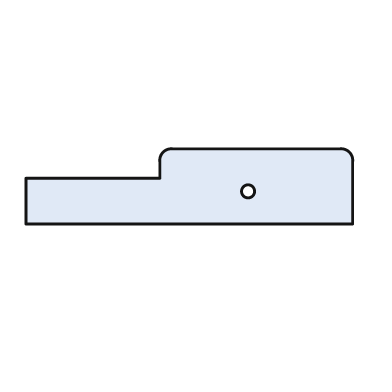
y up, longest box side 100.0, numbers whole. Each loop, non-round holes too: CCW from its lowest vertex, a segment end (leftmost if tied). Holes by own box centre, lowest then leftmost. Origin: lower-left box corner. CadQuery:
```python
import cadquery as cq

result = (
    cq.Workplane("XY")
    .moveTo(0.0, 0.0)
    .lineTo(100.0, 0.0)
    .lineTo(100.0, 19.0)
    .threePointArc((99.0, 22.0), (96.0, 23.0))
    .lineTo(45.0, 23.0)
    .threePointArc((42.0, 22.0), (41.0, 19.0))
    .lineTo(41.0, 14.0)
    .lineTo(0.0, 14.0)
    .close()
    .moveTo(68.0, 10.0)
    .circle(2.0)
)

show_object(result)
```